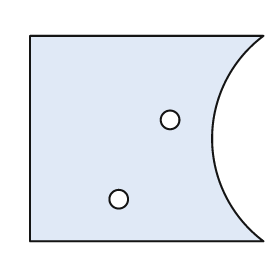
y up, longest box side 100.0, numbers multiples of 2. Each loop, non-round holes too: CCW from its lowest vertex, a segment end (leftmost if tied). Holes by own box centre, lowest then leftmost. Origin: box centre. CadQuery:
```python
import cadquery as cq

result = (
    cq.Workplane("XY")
    .moveTo(-50.0, -44.0)
    .lineTo(50.0, -44.0)
    .threePointArc((28.0, 0.0), (50.0, 44.0))
    .lineTo(-50.0, 44.0)
    .close()
    .moveTo(-12.0, -26.0)
    .circle(4.0)
    .moveTo(10.0, 8.0)
    .circle(4.0)
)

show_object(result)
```